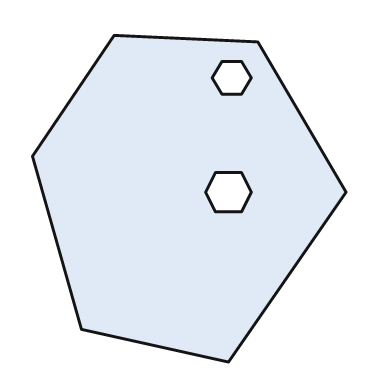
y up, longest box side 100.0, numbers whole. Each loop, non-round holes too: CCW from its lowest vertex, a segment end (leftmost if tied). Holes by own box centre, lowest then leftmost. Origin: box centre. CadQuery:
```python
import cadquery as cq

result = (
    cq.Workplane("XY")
    .moveTo(12.0, -50.0)
    .lineTo(48.0, 2.0)
    .lineTo(21.0, 48.0)
    .lineTo(-23.0, 50.0)
    .lineTo(-48.0, 13.0)
    .lineTo(-33.0, -40.0)
    .close()
    .moveTo(8.0, -4.0)
    .lineTo(16.0, -4.0)
    .lineTo(19.0, 2.0)
    .lineTo(16.0, 8.0)
    .lineTo(8.0, 8.0)
    .lineTo(5.0, 2.0)
    .close()
    .moveTo(10.0, 32.0)
    .lineTo(16.0, 32.0)
    .lineTo(19.0, 37.0)
    .lineTo(16.0, 42.0)
    .lineTo(10.0, 42.0)
    .lineTo(7.0, 37.0)
    .close()
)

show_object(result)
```